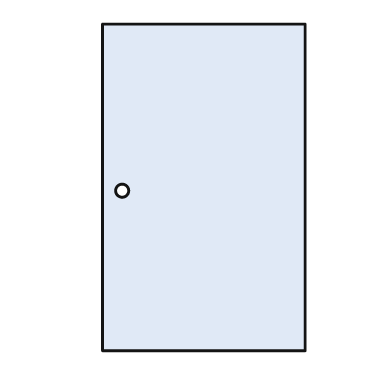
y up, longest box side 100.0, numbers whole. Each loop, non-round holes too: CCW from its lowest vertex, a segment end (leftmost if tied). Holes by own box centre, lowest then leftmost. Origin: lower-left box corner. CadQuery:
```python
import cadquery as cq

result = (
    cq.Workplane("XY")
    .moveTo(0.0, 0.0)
    .lineTo(62.0, 0.0)
    .lineTo(62.0, 100.0)
    .lineTo(0.0, 100.0)
    .close()
    .moveTo(6.0, 49.0)
    .circle(2.0)
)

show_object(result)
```